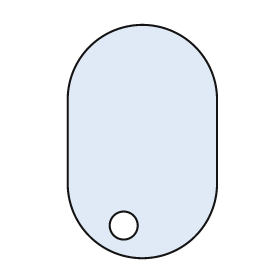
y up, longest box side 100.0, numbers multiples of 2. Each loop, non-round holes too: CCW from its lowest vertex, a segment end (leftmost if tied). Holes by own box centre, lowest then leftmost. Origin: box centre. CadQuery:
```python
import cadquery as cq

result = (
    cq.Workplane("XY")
    .moveTo(-32.0, -18.0)
    .threePointArc((0.0, -50.0), (32.0, -18.0))
    .lineTo(32.0, 18.0)
    .threePointArc((0.0, 50.0), (-32.0, 18.0))
    .close()
    .moveTo(-8.0, -36.0)
    .circle(6.0)
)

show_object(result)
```